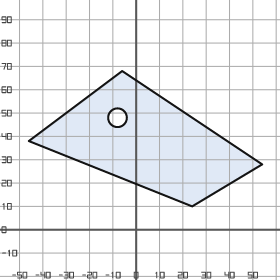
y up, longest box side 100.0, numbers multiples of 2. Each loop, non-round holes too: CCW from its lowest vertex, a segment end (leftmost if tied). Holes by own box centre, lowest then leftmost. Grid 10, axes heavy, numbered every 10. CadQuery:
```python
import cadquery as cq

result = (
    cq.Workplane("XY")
    .moveTo(24.0, 10.0)
    .lineTo(54.0, 28.0)
    .lineTo(-6.0, 68.0)
    .lineTo(-46.0, 38.0)
    .close()
    .moveTo(-8.0, 48.0)
    .circle(4.0)
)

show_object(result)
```